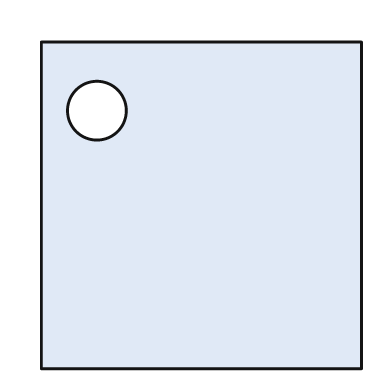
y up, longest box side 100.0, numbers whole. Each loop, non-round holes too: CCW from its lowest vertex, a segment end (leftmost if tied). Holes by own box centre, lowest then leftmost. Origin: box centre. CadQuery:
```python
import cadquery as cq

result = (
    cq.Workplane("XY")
    .moveTo(-49.0, -50.0)
    .lineTo(49.0, -50.0)
    .lineTo(49.0, 50.0)
    .lineTo(-49.0, 50.0)
    .close()
    .moveTo(-32.0, 29.0)
    .circle(9.0)
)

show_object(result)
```